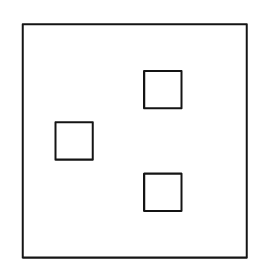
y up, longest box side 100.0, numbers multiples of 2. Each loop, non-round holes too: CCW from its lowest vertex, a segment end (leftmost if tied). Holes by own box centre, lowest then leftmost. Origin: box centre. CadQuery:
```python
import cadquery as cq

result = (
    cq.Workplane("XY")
    .moveTo(-48.0, -50.0)
    .lineTo(48.0, -50.0)
    .lineTo(48.0, 50.0)
    .lineTo(-48.0, 50.0)
    .close()
    .moveTo(4.0, -30.0)
    .lineTo(20.0, -30.0)
    .lineTo(20.0, -14.0)
    .lineTo(4.0, -14.0)
    .close()
    .moveTo(-34.0, -8.0)
    .lineTo(-18.0, -8.0)
    .lineTo(-18.0, 8.0)
    .lineTo(-34.0, 8.0)
    .close()
    .moveTo(4.0, 14.0)
    .lineTo(20.0, 14.0)
    .lineTo(20.0, 30.0)
    .lineTo(4.0, 30.0)
    .close()
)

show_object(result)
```